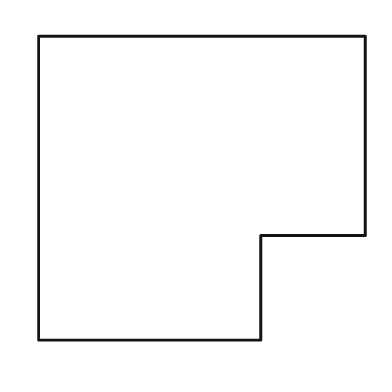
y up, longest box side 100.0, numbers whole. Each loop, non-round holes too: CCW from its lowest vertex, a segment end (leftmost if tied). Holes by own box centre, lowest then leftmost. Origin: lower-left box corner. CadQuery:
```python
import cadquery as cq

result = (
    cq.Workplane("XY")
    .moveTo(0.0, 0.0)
    .lineTo(68.0, 0.0)
    .lineTo(68.0, 32.0)
    .lineTo(100.0, 32.0)
    .lineTo(100.0, 93.0)
    .lineTo(0.0, 93.0)
    .close()
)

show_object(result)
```